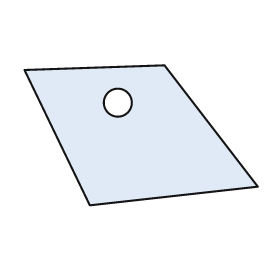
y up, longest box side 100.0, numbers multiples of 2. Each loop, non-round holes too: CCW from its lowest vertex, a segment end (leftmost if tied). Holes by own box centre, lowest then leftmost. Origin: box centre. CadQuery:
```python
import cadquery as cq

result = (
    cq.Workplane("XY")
    .moveTo(-22.0, -30.0)
    .lineTo(50.0, -22.0)
    .lineTo(10.0, 30.0)
    .lineTo(-50.0, 28.0)
    .close()
    .moveTo(-10.0, 14.0)
    .circle(6.0)
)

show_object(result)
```